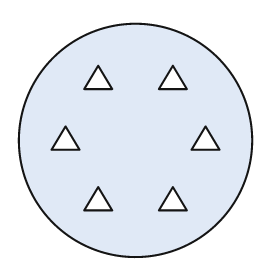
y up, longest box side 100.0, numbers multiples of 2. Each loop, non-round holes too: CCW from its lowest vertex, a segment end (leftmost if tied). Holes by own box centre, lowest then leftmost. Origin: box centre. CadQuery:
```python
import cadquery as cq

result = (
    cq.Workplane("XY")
    .moveTo(0.0, 0.0)
    .circle(50.0)
    .moveTo(-22.0, -30.0)
    .lineTo(-10.0, -30.0)
    .lineTo(-16.0, -20.0)
    .close()
    .moveTo(10.0, -30.0)
    .lineTo(22.0, -30.0)
    .lineTo(16.0, -20.0)
    .close()
    .moveTo(-36.0, -4.0)
    .lineTo(-24.0, -4.0)
    .lineTo(-30.0, 6.0)
    .close()
    .moveTo(24.0, -4.0)
    .lineTo(36.0, -4.0)
    .lineTo(30.0, 6.0)
    .close()
    .moveTo(-22.0, 22.0)
    .lineTo(-10.0, 22.0)
    .lineTo(-16.0, 32.0)
    .close()
    .moveTo(10.0, 22.0)
    .lineTo(22.0, 22.0)
    .lineTo(16.0, 32.0)
    .close()
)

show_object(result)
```